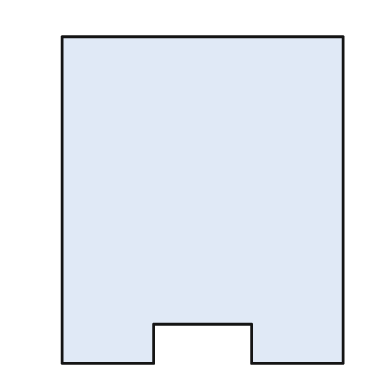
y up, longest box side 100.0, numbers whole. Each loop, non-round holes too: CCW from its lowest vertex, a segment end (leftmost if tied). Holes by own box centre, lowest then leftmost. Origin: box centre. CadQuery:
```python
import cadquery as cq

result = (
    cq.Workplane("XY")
    .moveTo(-43.0, -50.0)
    .lineTo(-15.0, -50.0)
    .lineTo(-15.0, -38.0)
    .lineTo(15.0, -38.0)
    .lineTo(15.0, -50.0)
    .lineTo(43.0, -50.0)
    .lineTo(43.0, 50.0)
    .lineTo(-43.0, 50.0)
    .close()
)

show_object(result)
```